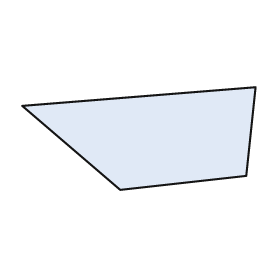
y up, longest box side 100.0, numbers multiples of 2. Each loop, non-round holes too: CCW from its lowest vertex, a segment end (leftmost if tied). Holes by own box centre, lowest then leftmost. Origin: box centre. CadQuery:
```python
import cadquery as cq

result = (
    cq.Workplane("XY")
    .moveTo(-8.0, -22.0)
    .lineTo(46.0, -16.0)
    .lineTo(50.0, 22.0)
    .lineTo(-50.0, 14.0)
    .close()
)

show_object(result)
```